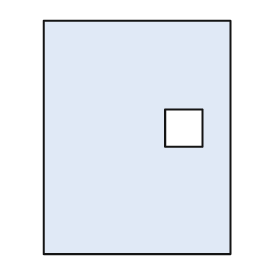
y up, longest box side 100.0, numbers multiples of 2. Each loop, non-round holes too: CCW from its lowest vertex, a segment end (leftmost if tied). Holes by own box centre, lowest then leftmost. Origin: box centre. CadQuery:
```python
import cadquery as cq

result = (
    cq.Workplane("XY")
    .moveTo(-40.0, -50.0)
    .lineTo(40.0, -50.0)
    .lineTo(40.0, 50.0)
    .lineTo(-40.0, 50.0)
    .close()
    .moveTo(12.0, -4.0)
    .lineTo(28.0, -4.0)
    .lineTo(28.0, 12.0)
    .lineTo(12.0, 12.0)
    .close()
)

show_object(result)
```